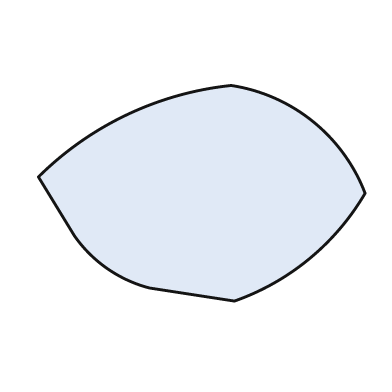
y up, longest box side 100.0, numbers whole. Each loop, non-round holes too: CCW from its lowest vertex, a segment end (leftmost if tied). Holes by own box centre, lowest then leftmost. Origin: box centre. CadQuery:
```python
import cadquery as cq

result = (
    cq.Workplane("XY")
    .moveTo(10.0, -33.0)
    .threePointArc((33.0, -20.0), (50.0, 0.0))
    .threePointArc((34.0, 22.0), (9.0, 33.0))
    .threePointArc((-23.0, 24.0), (-50.0, 5.0))
    .lineTo(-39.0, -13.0)
    .threePointArc((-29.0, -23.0), (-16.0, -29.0))
    .close()
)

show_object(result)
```